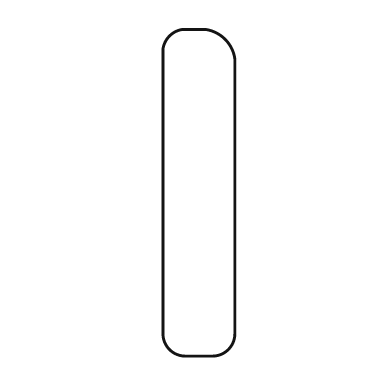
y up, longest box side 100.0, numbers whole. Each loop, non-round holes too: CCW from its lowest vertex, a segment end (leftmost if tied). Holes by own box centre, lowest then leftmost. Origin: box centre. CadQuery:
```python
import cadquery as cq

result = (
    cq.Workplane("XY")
    .moveTo(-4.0, -50.0)
    .lineTo(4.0, -50.0)
    .threePointArc((9.0, -48.0), (11.0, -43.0))
    .lineTo(11.0, 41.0)
    .threePointArc((8.0, 47.0), (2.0, 50.0))
    .lineTo(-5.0, 50.0)
    .threePointArc((-9.0, 48.0), (-11.0, 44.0))
    .lineTo(-11.0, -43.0)
    .threePointArc((-9.0, -48.0), (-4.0, -50.0))
    .close()
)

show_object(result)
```